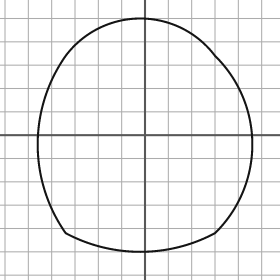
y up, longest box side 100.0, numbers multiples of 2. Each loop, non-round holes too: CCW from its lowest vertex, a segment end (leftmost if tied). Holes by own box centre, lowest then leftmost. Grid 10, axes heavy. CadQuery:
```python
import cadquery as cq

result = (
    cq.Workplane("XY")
    .moveTo(-34.0, -42.0)
    .threePointArc((-2.0, -50.0), (30.0, -42.0))
    .threePointArc((46.0, -4.0), (30.0, 34.0))
    .threePointArc((-2.0, 50.0), (-34.0, 34.0))
    .threePointArc((-46.0, -4.0), (-34.0, -42.0))
    .close()
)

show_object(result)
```